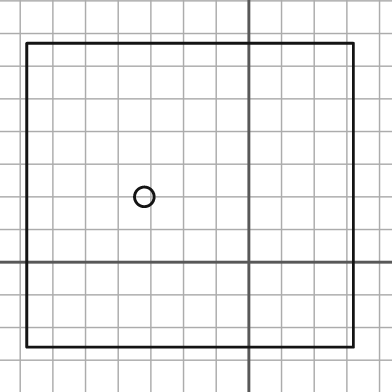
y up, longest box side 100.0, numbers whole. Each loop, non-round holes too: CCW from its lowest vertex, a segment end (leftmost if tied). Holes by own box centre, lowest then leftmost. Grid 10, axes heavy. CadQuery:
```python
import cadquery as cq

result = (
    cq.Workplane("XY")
    .moveTo(-68.0, -26.0)
    .lineTo(32.0, -26.0)
    .lineTo(32.0, 67.0)
    .lineTo(-68.0, 67.0)
    .close()
    .moveTo(-32.0, 20.0)
    .circle(3.0)
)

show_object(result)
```